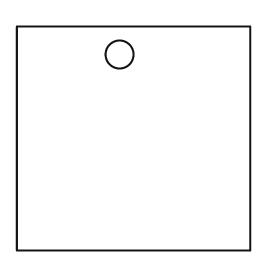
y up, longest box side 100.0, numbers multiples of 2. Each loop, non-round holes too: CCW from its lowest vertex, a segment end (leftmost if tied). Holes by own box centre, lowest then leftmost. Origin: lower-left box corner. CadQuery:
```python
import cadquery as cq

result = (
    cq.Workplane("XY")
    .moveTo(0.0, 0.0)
    .lineTo(100.0, 0.0)
    .lineTo(100.0, 96.0)
    .lineTo(0.0, 96.0)
    .close()
    .moveTo(44.0, 84.0)
    .circle(6.0)
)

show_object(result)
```